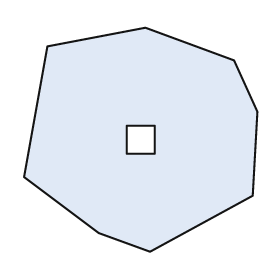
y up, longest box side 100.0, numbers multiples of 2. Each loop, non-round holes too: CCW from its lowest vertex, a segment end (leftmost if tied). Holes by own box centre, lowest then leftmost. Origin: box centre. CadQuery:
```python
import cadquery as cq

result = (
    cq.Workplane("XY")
    .moveTo(4.0, -48.0)
    .lineTo(48.0, -24.0)
    .lineTo(50.0, 12.0)
    .lineTo(40.0, 34.0)
    .lineTo(2.0, 48.0)
    .lineTo(-40.0, 40.0)
    .lineTo(-50.0, -16.0)
    .lineTo(-18.0, -40.0)
    .close()
    .moveTo(-6.0, -6.0)
    .lineTo(6.0, -6.0)
    .lineTo(6.0, 6.0)
    .lineTo(-6.0, 6.0)
    .close()
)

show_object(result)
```